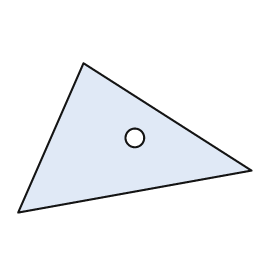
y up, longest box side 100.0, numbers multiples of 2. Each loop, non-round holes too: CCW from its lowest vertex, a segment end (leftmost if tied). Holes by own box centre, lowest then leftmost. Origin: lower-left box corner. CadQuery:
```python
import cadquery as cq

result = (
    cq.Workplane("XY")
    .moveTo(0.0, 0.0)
    .lineTo(100.0, 18.0)
    .lineTo(28.0, 64.0)
    .close()
    .moveTo(50.0, 32.0)
    .circle(4.0)
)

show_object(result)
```